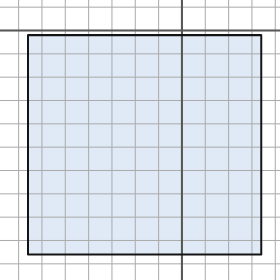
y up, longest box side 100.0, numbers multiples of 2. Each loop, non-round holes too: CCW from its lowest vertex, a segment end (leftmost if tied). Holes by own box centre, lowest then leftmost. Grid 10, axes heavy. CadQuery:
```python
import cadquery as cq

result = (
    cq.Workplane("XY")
    .moveTo(-66.0, -96.0)
    .lineTo(34.0, -96.0)
    .lineTo(34.0, -2.0)
    .lineTo(-66.0, -2.0)
    .close()
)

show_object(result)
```